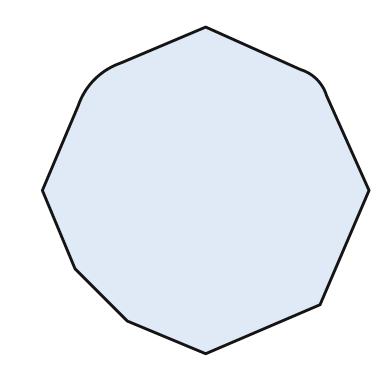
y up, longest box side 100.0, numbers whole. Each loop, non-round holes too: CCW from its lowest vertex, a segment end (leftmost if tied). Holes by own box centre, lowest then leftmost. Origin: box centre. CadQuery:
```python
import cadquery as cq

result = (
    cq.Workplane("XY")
    .moveTo(0.0, -50.0)
    .lineTo(35.0, -35.0)
    .lineTo(50.0, 0.0)
    .lineTo(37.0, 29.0)
    .threePointArc((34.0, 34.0), (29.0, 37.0))
    .lineTo(0.0, 50.0)
    .lineTo(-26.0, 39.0)
    .threePointArc((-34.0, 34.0), (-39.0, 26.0))
    .lineTo(-50.0, 0.0)
    .lineTo(-40.0, -24.0)
    .lineTo(-24.0, -40.0)
    .close()
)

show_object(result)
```